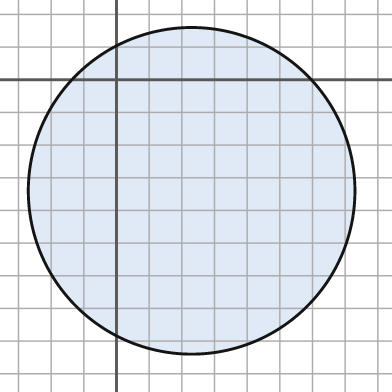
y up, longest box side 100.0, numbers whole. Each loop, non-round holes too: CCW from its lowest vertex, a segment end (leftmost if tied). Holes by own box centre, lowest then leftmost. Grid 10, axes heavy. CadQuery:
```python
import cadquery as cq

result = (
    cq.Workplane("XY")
    .moveTo(23.0, -34.0)
    .circle(50.0)
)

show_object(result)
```